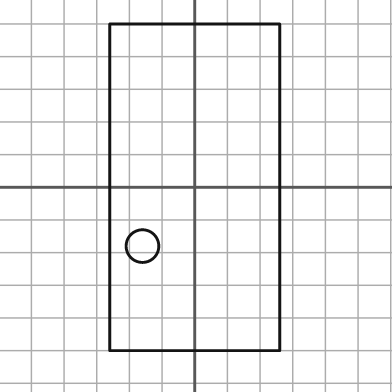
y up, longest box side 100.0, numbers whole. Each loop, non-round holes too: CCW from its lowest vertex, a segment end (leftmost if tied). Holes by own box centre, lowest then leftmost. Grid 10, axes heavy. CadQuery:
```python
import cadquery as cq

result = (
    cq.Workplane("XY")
    .moveTo(-26.0, -50.0)
    .lineTo(26.0, -50.0)
    .lineTo(26.0, 50.0)
    .lineTo(-26.0, 50.0)
    .close()
    .moveTo(-16.0, -18.0)
    .circle(5.0)
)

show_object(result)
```